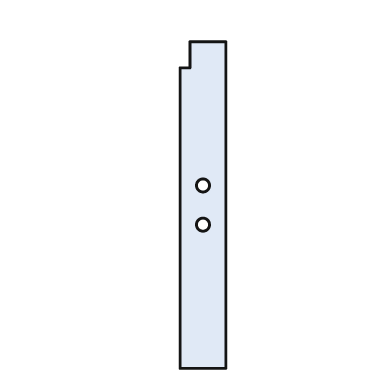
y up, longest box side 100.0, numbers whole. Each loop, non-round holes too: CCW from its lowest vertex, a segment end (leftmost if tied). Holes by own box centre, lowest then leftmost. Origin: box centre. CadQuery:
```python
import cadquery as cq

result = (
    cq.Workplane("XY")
    .moveTo(-7.0, -50.0)
    .lineTo(7.0, -50.0)
    .lineTo(7.0, 50.0)
    .lineTo(-4.0, 50.0)
    .lineTo(-4.0, 42.0)
    .lineTo(-7.0, 42.0)
    .close()
    .moveTo(0.0, -6.0)
    .circle(2.0)
    .moveTo(0.0, 6.0)
    .circle(2.0)
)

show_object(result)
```